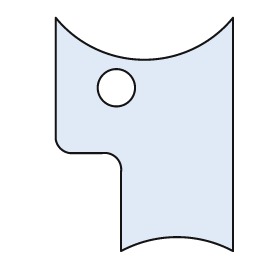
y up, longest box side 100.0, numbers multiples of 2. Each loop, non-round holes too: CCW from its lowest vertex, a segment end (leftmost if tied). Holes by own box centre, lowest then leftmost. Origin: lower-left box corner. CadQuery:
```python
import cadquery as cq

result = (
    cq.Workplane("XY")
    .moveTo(28.0, 0.0)
    .threePointArc((52.0, 6.0), (76.0, 0.0))
    .lineTo(76.0, 100.0)
    .threePointArc((38.0, 82.0), (0.0, 100.0))
    .lineTo(0.0, 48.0)
    .threePointArc((2.0, 44.0), (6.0, 42.0))
    .lineTo(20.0, 42.0)
    .threePointArc((26.0, 40.0), (28.0, 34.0))
    .close()
    .moveTo(26.0, 70.0)
    .circle(8.0)
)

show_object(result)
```